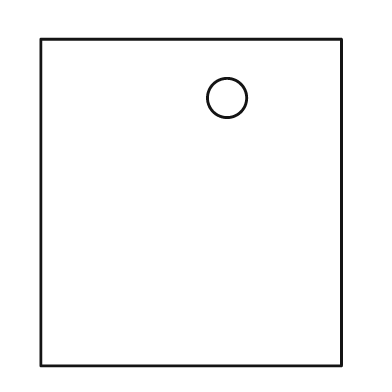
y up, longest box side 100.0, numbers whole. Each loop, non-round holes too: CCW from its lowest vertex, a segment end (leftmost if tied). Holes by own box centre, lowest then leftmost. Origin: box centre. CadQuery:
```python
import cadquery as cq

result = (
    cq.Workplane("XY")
    .moveTo(-46.0, -50.0)
    .lineTo(46.0, -50.0)
    .lineTo(46.0, 50.0)
    .lineTo(-46.0, 50.0)
    .close()
    .moveTo(11.0, 32.0)
    .circle(6.0)
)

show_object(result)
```